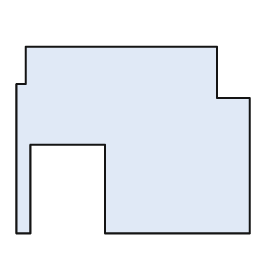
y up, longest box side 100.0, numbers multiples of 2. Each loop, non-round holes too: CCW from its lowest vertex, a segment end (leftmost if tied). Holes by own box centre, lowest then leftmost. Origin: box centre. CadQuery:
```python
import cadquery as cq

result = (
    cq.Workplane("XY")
    .moveTo(-50.0, -40.0)
    .lineTo(-44.0, -40.0)
    .lineTo(-44.0, -2.0)
    .lineTo(-12.0, -2.0)
    .lineTo(-12.0, -40.0)
    .lineTo(50.0, -40.0)
    .lineTo(50.0, 18.0)
    .lineTo(36.0, 18.0)
    .lineTo(36.0, 40.0)
    .lineTo(-46.0, 40.0)
    .lineTo(-46.0, 24.0)
    .lineTo(-50.0, 24.0)
    .close()
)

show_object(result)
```